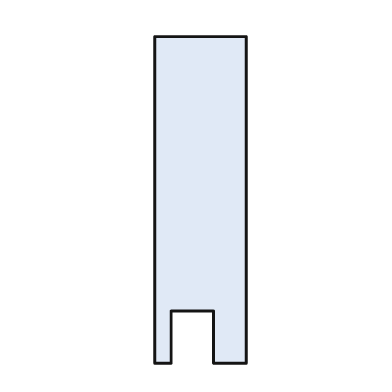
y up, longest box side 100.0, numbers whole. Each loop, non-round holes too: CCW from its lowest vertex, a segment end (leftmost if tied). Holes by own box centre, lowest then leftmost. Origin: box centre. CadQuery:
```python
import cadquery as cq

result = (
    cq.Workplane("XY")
    .moveTo(-14.0, -50.0)
    .lineTo(-9.0, -50.0)
    .lineTo(-9.0, -34.0)
    .lineTo(4.0, -34.0)
    .lineTo(4.0, -50.0)
    .lineTo(14.0, -50.0)
    .lineTo(14.0, 50.0)
    .lineTo(-14.0, 50.0)
    .close()
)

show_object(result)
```